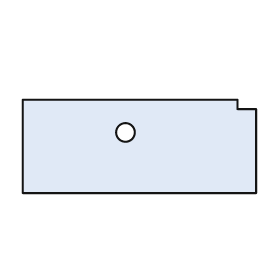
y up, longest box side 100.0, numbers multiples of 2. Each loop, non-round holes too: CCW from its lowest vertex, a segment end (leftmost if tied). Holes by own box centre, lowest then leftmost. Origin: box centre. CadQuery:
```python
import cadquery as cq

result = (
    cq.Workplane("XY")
    .moveTo(-50.0, -20.0)
    .lineTo(50.0, -20.0)
    .lineTo(50.0, 16.0)
    .lineTo(42.0, 16.0)
    .lineTo(42.0, 20.0)
    .lineTo(-50.0, 20.0)
    .close()
    .moveTo(-6.0, 6.0)
    .circle(4.0)
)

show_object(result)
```